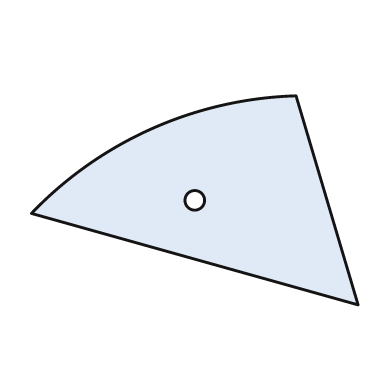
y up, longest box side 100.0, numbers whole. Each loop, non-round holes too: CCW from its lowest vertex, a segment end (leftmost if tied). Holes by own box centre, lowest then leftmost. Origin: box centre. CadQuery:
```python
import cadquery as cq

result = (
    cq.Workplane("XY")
    .moveTo(50.0, -32.0)
    .lineTo(31.0, 32.0)
    .threePointArc((-13.0, 22.0), (-50.0, -4.0))
    .close()
    .moveTo(0.0, 0.0)
    .circle(3.0)
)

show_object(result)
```